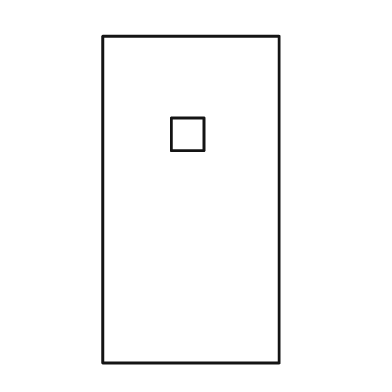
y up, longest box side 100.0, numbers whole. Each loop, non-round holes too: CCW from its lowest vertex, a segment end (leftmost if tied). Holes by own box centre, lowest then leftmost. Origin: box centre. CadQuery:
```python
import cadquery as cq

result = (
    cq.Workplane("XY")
    .moveTo(-27.0, -50.0)
    .lineTo(27.0, -50.0)
    .lineTo(27.0, 50.0)
    .lineTo(-27.0, 50.0)
    .close()
    .moveTo(-6.0, 15.0)
    .lineTo(4.0, 15.0)
    .lineTo(4.0, 25.0)
    .lineTo(-6.0, 25.0)
    .close()
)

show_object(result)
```